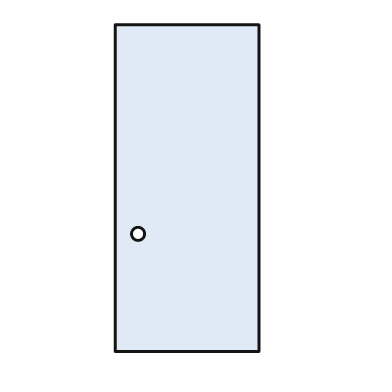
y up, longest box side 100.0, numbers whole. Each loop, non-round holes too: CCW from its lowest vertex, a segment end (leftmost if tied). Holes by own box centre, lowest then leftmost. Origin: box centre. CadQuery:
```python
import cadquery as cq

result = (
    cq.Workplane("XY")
    .moveTo(-22.0, -50.0)
    .lineTo(22.0, -50.0)
    .lineTo(22.0, 50.0)
    .lineTo(-22.0, 50.0)
    .close()
    .moveTo(-15.0, -14.0)
    .circle(2.0)
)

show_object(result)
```